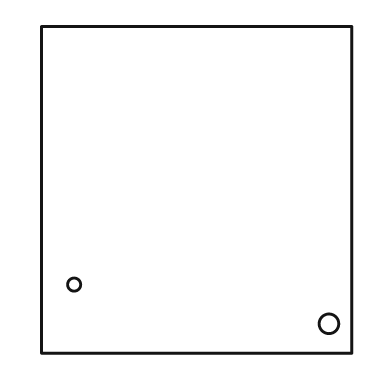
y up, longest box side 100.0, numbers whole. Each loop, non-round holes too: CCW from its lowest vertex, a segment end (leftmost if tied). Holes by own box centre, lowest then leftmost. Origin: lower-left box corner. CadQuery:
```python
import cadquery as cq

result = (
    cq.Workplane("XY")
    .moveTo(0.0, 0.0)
    .lineTo(95.0, 0.0)
    .lineTo(95.0, 100.0)
    .lineTo(0.0, 100.0)
    .close()
    .moveTo(88.0, 9.0)
    .circle(3.0)
    .moveTo(10.0, 21.0)
    .circle(2.0)
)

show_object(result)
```